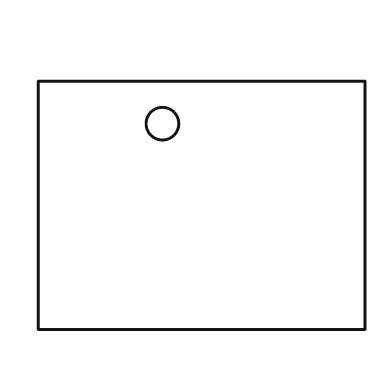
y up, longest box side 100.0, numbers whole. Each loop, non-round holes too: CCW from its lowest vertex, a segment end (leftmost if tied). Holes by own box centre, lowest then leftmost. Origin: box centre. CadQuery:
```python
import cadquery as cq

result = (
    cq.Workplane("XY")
    .moveTo(-50.0, -38.0)
    .lineTo(50.0, -38.0)
    .lineTo(50.0, 38.0)
    .lineTo(-50.0, 38.0)
    .close()
    .moveTo(-12.0, 25.0)
    .circle(5.0)
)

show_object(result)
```